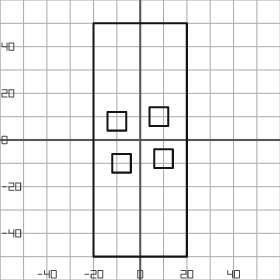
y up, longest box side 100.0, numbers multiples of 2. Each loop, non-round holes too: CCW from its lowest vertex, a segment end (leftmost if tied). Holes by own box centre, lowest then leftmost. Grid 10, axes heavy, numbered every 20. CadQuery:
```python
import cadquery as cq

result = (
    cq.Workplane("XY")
    .moveTo(-20.0, -50.0)
    .lineTo(20.0, -50.0)
    .lineTo(20.0, 50.0)
    .lineTo(-20.0, 50.0)
    .close()
    .moveTo(-12.0, -14.0)
    .lineTo(-4.0, -14.0)
    .lineTo(-4.0, -6.0)
    .lineTo(-12.0, -6.0)
    .close()
    .moveTo(6.0, -12.0)
    .lineTo(14.0, -12.0)
    .lineTo(14.0, -4.0)
    .lineTo(6.0, -4.0)
    .close()
    .moveTo(-14.0, 4.0)
    .lineTo(-6.0, 4.0)
    .lineTo(-6.0, 12.0)
    .lineTo(-14.0, 12.0)
    .close()
    .moveTo(4.0, 6.0)
    .lineTo(12.0, 6.0)
    .lineTo(12.0, 14.0)
    .lineTo(4.0, 14.0)
    .close()
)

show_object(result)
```